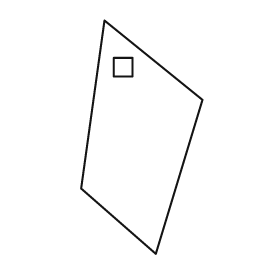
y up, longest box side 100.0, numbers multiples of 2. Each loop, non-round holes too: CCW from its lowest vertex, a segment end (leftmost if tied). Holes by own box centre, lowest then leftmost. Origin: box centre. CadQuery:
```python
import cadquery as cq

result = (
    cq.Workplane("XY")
    .moveTo(6.0, -50.0)
    .lineTo(26.0, 16.0)
    .lineTo(-16.0, 50.0)
    .lineTo(-26.0, -22.0)
    .close()
    .moveTo(-12.0, 26.0)
    .lineTo(-4.0, 26.0)
    .lineTo(-4.0, 34.0)
    .lineTo(-12.0, 34.0)
    .close()
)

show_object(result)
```